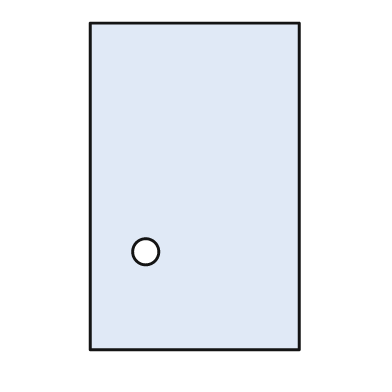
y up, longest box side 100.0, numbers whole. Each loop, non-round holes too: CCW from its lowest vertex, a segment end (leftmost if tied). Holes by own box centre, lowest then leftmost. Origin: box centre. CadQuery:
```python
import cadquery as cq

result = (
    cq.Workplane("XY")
    .moveTo(-32.0, -50.0)
    .lineTo(32.0, -50.0)
    .lineTo(32.0, 50.0)
    .lineTo(-32.0, 50.0)
    .close()
    .moveTo(-15.0, -20.0)
    .circle(4.0)
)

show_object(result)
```